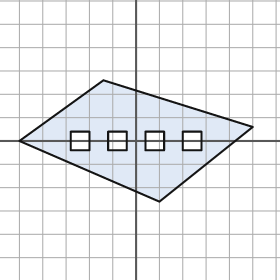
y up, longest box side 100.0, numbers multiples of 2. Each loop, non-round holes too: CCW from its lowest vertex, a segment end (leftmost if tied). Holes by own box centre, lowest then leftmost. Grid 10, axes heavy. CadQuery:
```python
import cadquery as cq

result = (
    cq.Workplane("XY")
    .moveTo(10.0, -26.0)
    .lineTo(50.0, 6.0)
    .lineTo(-14.0, 26.0)
    .lineTo(-50.0, 0.0)
    .close()
    .moveTo(-28.0, -4.0)
    .lineTo(-20.0, -4.0)
    .lineTo(-20.0, 4.0)
    .lineTo(-28.0, 4.0)
    .close()
    .moveTo(-12.0, -4.0)
    .lineTo(-4.0, -4.0)
    .lineTo(-4.0, 4.0)
    .lineTo(-12.0, 4.0)
    .close()
    .moveTo(4.0, -4.0)
    .lineTo(12.0, -4.0)
    .lineTo(12.0, 4.0)
    .lineTo(4.0, 4.0)
    .close()
    .moveTo(20.0, -4.0)
    .lineTo(28.0, -4.0)
    .lineTo(28.0, 4.0)
    .lineTo(20.0, 4.0)
    .close()
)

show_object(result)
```